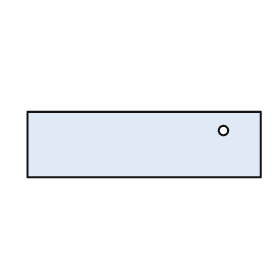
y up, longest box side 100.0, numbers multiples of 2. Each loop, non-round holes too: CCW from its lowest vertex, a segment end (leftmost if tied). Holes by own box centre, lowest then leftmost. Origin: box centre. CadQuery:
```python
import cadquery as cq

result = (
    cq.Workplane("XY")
    .moveTo(-50.0, -14.0)
    .lineTo(50.0, -14.0)
    .lineTo(50.0, 14.0)
    .lineTo(-50.0, 14.0)
    .close()
    .moveTo(34.0, 6.0)
    .circle(2.0)
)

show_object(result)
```